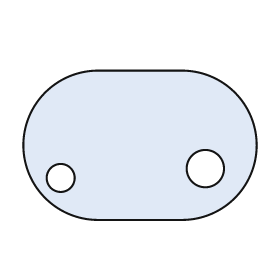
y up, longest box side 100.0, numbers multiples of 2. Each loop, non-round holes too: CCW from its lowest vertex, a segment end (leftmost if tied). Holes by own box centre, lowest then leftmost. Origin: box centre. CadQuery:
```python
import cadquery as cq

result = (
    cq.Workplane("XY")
    .moveTo(-18.0, -32.0)
    .lineTo(18.0, -32.0)
    .threePointArc((50.0, 0.0), (18.0, 32.0))
    .lineTo(-18.0, 32.0)
    .threePointArc((-50.0, 0.0), (-18.0, -32.0))
    .close()
    .moveTo(-34.0, -14.0)
    .circle(6.0)
    .moveTo(28.0, -10.0)
    .circle(8.0)
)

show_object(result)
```